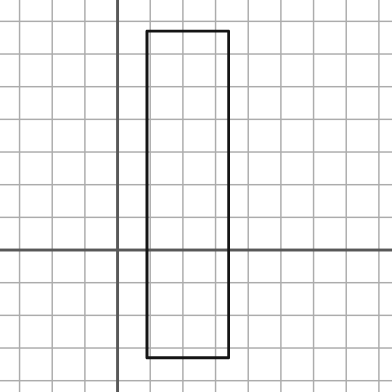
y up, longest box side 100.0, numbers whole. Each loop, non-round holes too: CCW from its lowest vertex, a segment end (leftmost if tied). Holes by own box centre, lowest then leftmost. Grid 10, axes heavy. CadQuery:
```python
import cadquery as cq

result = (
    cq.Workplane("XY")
    .moveTo(9.0, -33.0)
    .lineTo(34.0, -33.0)
    .lineTo(34.0, 67.0)
    .lineTo(9.0, 67.0)
    .close()
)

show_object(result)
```